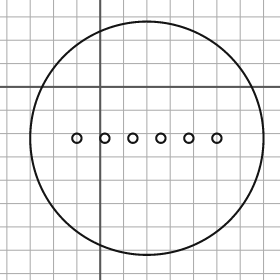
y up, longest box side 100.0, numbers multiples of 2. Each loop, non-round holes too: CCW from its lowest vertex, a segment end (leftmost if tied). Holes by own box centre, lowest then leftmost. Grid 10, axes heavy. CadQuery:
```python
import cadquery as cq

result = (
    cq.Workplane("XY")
    .moveTo(20.0, -22.0)
    .circle(50.0)
    .moveTo(-10.0, -22.0)
    .circle(2.0)
    .moveTo(2.0, -22.0)
    .circle(2.0)
    .moveTo(14.0, -22.0)
    .circle(2.0)
    .moveTo(26.0, -22.0)
    .circle(2.0)
    .moveTo(38.0, -22.0)
    .circle(2.0)
    .moveTo(50.0, -22.0)
    .circle(2.0)
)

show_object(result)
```